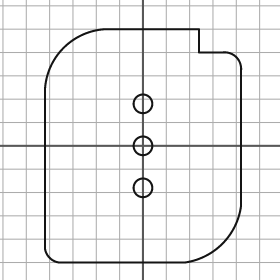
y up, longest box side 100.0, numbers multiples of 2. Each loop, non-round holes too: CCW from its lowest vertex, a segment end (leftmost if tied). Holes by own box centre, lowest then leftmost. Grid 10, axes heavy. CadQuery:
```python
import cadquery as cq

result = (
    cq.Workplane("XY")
    .moveTo(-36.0, -50.0)
    .lineTo(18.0, -50.0)
    .threePointArc((34.0, -42.0), (42.0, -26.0))
    .lineTo(42.0, 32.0)
    .threePointArc((40.0, 38.0), (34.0, 40.0))
    .lineTo(24.0, 40.0)
    .lineTo(24.0, 50.0)
    .lineTo(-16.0, 50.0)
    .threePointArc((-34.0, 42.0), (-42.0, 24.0))
    .lineTo(-42.0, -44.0)
    .threePointArc((-40.0, -48.0), (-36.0, -50.0))
    .close()
    .moveTo(0.0, -18.0)
    .circle(4.0)
    .moveTo(0.0, 0.0)
    .circle(4.0)
    .moveTo(0.0, 18.0)
    .circle(4.0)
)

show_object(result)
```